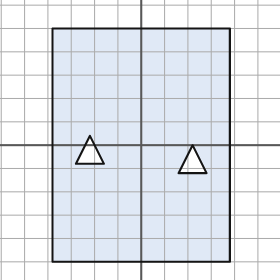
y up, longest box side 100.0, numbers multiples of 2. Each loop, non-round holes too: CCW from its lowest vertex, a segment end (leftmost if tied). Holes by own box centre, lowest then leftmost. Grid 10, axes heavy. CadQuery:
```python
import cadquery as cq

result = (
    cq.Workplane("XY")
    .moveTo(-38.0, -50.0)
    .lineTo(38.0, -50.0)
    .lineTo(38.0, 50.0)
    .lineTo(-38.0, 50.0)
    .close()
    .moveTo(16.0, -12.0)
    .lineTo(28.0, -12.0)
    .lineTo(22.0, 0.0)
    .close()
    .moveTo(-28.0, -8.0)
    .lineTo(-16.0, -8.0)
    .lineTo(-22.0, 4.0)
    .close()
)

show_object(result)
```